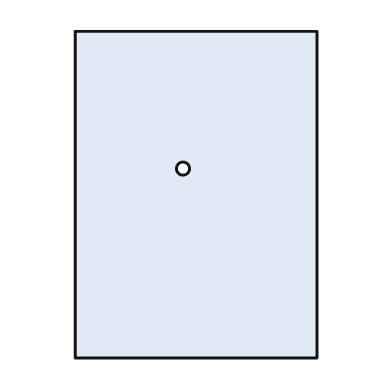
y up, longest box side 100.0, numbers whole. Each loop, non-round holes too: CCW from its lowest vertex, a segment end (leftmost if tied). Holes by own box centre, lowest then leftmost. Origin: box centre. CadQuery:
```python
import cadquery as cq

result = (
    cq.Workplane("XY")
    .moveTo(-37.0, -50.0)
    .lineTo(37.0, -50.0)
    .lineTo(37.0, 50.0)
    .lineTo(-37.0, 50.0)
    .close()
    .moveTo(-4.0, 8.0)
    .circle(2.0)
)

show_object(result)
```